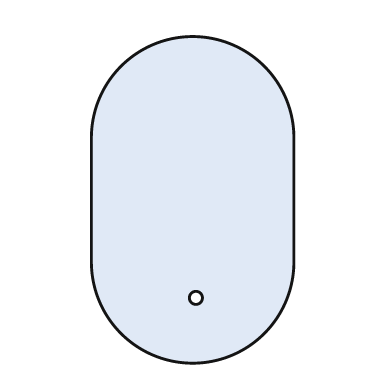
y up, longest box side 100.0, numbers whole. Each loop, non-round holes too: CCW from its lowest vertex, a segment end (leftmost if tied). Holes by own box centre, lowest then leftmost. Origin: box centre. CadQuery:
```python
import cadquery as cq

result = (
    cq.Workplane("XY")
    .moveTo(-31.0, -19.0)
    .threePointArc((0.0, -50.0), (31.0, -19.0))
    .lineTo(31.0, 19.0)
    .threePointArc((0.0, 50.0), (-31.0, 19.0))
    .close()
    .moveTo(1.0, -30.0)
    .circle(2.0)
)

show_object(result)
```